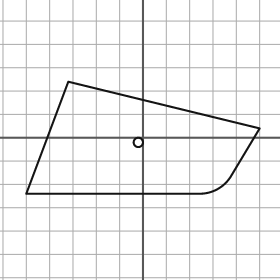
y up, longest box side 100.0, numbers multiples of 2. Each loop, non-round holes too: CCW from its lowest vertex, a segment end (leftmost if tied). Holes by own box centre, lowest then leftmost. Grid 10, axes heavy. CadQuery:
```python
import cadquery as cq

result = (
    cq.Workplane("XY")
    .moveTo(-50.0, -24.0)
    .lineTo(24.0, -24.0)
    .threePointArc((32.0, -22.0), (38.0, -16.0))
    .lineTo(50.0, 4.0)
    .lineTo(-32.0, 24.0)
    .close()
    .moveTo(-2.0, -2.0)
    .circle(2.0)
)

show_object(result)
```